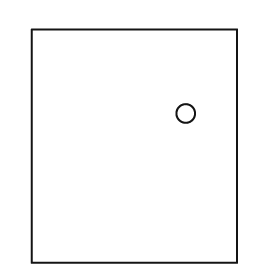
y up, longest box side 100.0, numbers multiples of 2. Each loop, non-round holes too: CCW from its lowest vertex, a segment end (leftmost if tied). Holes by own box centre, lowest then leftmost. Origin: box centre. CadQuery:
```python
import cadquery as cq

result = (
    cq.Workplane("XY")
    .moveTo(-44.0, -50.0)
    .lineTo(44.0, -50.0)
    .lineTo(44.0, 50.0)
    .lineTo(-44.0, 50.0)
    .close()
    .moveTo(22.0, 14.0)
    .circle(4.0)
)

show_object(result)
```